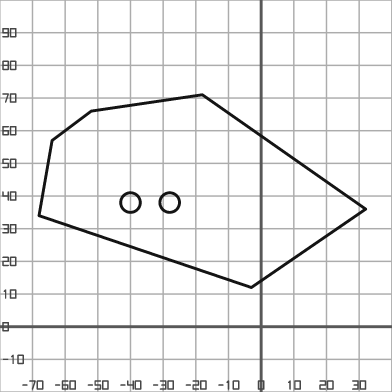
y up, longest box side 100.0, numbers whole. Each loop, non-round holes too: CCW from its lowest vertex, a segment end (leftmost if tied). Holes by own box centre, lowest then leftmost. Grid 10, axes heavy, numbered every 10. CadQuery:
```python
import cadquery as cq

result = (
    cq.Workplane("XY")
    .moveTo(-3.0, 12.0)
    .lineTo(32.0, 36.0)
    .lineTo(-18.0, 71.0)
    .lineTo(-52.0, 66.0)
    .lineTo(-64.0, 57.0)
    .lineTo(-68.0, 34.0)
    .close()
    .moveTo(-40.0, 38.0)
    .circle(3.0)
    .moveTo(-28.0, 38.0)
    .circle(3.0)
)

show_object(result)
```